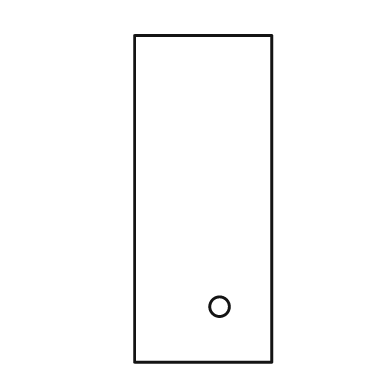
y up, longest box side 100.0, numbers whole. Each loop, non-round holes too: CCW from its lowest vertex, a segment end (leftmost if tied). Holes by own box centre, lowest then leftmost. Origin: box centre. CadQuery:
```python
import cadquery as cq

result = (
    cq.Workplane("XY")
    .moveTo(-21.0, -50.0)
    .lineTo(21.0, -50.0)
    .lineTo(21.0, 50.0)
    .lineTo(-21.0, 50.0)
    .close()
    .moveTo(5.0, -33.0)
    .circle(3.0)
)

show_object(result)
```